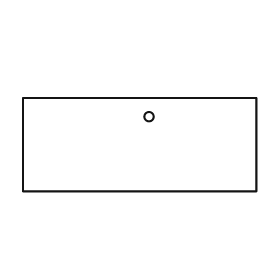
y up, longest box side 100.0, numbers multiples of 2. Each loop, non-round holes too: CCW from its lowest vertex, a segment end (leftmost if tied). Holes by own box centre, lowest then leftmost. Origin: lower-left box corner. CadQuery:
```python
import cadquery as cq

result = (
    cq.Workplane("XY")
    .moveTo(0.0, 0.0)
    .lineTo(100.0, 0.0)
    .lineTo(100.0, 40.0)
    .lineTo(0.0, 40.0)
    .close()
    .moveTo(54.0, 32.0)
    .circle(2.0)
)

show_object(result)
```